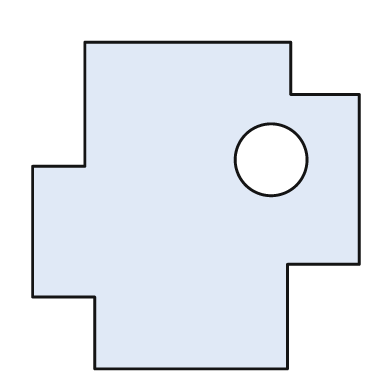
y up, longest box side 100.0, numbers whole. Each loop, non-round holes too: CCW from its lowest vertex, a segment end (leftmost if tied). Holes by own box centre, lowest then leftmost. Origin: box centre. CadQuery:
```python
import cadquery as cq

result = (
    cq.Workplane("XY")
    .moveTo(-31.0, -50.0)
    .lineTo(28.0, -50.0)
    .lineTo(28.0, -18.0)
    .lineTo(50.0, -18.0)
    .lineTo(50.0, 34.0)
    .lineTo(29.0, 34.0)
    .lineTo(29.0, 50.0)
    .lineTo(-34.0, 50.0)
    .lineTo(-34.0, 12.0)
    .lineTo(-50.0, 12.0)
    .lineTo(-50.0, -28.0)
    .lineTo(-31.0, -28.0)
    .close()
    .moveTo(23.0, 14.0)
    .circle(11.0)
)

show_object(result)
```